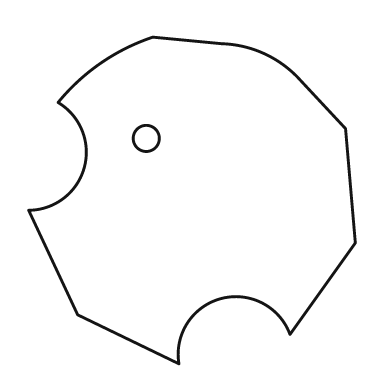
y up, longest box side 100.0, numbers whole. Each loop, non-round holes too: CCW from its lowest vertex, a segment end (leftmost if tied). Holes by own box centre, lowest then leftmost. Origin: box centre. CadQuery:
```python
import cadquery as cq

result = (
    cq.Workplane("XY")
    .moveTo(-4.0, -50.0)
    .threePointArc((9.0, -30.0), (30.0, -41.0))
    .lineTo(50.0, -13.0)
    .lineTo(47.0, 22.0)
    .lineTo(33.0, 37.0)
    .threePointArc((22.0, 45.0), (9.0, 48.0))
    .lineTo(-12.0, 50.0)
    .threePointArc((-28.0, 42.0), (-41.0, 30.0))
    .threePointArc((-33.0, 10.0), (-50.0, -3.0))
    .lineTo(-35.0, -35.0)
    .close()
    .moveTo(-14.0, 19.0)
    .circle(4.0)
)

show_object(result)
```